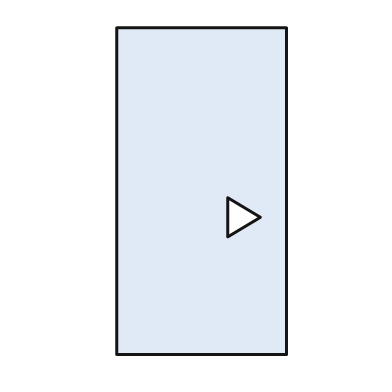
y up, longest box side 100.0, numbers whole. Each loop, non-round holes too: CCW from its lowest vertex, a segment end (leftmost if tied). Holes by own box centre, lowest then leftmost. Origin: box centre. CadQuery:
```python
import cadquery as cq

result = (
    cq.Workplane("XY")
    .moveTo(-26.0, -50.0)
    .lineTo(26.0, -50.0)
    .lineTo(26.0, 50.0)
    .lineTo(-26.0, 50.0)
    .close()
    .moveTo(8.0, -14.0)
    .lineTo(18.0, -8.0)
    .lineTo(8.0, -2.0)
    .close()
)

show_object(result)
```